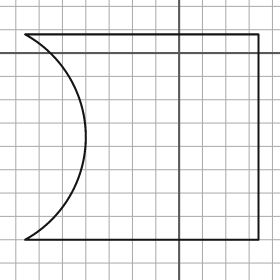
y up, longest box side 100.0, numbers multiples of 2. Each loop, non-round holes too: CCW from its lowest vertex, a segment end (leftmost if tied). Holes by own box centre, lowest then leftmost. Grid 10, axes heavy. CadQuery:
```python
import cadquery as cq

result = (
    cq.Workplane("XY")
    .moveTo(-66.0, -80.0)
    .lineTo(34.0, -80.0)
    .lineTo(34.0, 8.0)
    .lineTo(-66.0, 8.0)
    .threePointArc((-40.0, -36.0), (-66.0, -80.0))
    .close()
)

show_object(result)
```